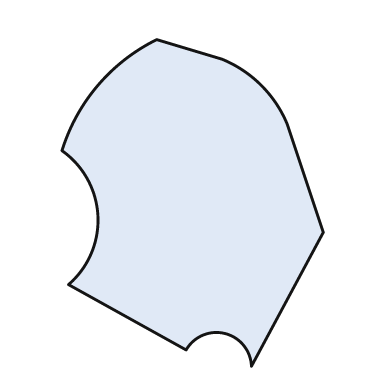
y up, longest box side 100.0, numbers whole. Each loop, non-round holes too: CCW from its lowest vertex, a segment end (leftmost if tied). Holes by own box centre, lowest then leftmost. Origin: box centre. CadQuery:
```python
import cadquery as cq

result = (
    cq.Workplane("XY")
    .moveTo(18.0, -50.0)
    .lineTo(40.0, -9.0)
    .lineTo(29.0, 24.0)
    .threePointArc((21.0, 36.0), (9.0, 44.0))
    .lineTo(-11.0, 50.0)
    .threePointArc((-29.0, 36.0), (-40.0, 16.0))
    .threePointArc((-29.0, -4.0), (-38.0, -25.0))
    .lineTo(-2.0, -45.0)
    .threePointArc((10.0, -40.0), (18.0, -50.0))
    .close()
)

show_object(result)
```